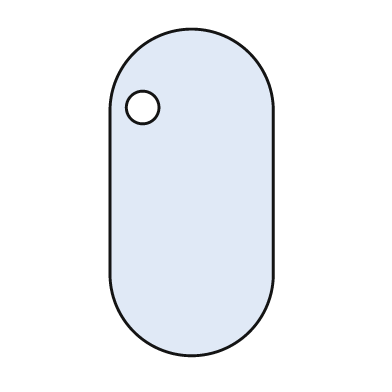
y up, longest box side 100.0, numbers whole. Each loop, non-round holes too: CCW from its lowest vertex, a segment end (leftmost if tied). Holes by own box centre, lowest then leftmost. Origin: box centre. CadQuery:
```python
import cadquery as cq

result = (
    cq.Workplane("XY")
    .moveTo(-25.0, -25.0)
    .threePointArc((0.0, -50.0), (25.0, -25.0))
    .lineTo(25.0, 25.0)
    .threePointArc((0.0, 50.0), (-25.0, 25.0))
    .close()
    .moveTo(-15.0, 26.0)
    .circle(5.0)
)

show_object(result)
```